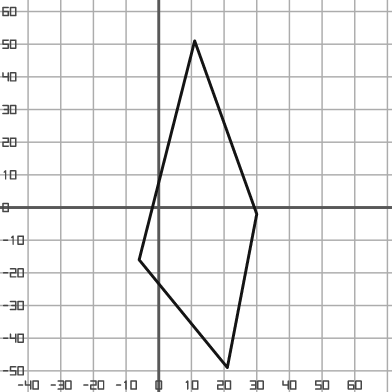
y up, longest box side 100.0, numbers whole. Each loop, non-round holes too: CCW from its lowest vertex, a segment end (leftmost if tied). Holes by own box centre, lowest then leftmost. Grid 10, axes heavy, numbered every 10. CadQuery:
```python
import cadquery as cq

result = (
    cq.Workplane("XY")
    .moveTo(21.0, -49.0)
    .lineTo(30.0, -2.0)
    .lineTo(11.0, 51.0)
    .lineTo(-6.0, -16.0)
    .close()
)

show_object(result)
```